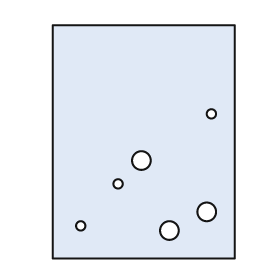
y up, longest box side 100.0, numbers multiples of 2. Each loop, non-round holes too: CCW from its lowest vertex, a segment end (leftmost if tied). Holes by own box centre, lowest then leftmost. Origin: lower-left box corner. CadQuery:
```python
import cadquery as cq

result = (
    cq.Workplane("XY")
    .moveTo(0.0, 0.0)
    .lineTo(78.0, 0.0)
    .lineTo(78.0, 100.0)
    .lineTo(0.0, 100.0)
    .close()
    .moveTo(50.0, 12.0)
    .circle(4.0)
    .moveTo(12.0, 14.0)
    .circle(2.0)
    .moveTo(66.0, 20.0)
    .circle(4.0)
    .moveTo(28.0, 32.0)
    .circle(2.0)
    .moveTo(38.0, 42.0)
    .circle(4.0)
    .moveTo(68.0, 62.0)
    .circle(2.0)
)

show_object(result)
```